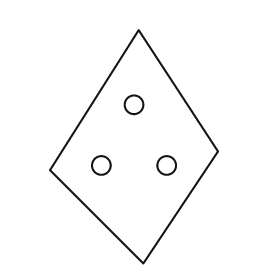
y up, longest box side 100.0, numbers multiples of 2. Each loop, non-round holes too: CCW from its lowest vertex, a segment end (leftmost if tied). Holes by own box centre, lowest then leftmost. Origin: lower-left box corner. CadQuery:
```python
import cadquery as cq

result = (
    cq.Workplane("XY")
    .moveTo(40.0, 0.0)
    .lineTo(72.0, 48.0)
    .lineTo(38.0, 100.0)
    .lineTo(0.0, 40.0)
    .close()
    .moveTo(22.0, 42.0)
    .circle(4.0)
    .moveTo(50.0, 42.0)
    .circle(4.0)
    .moveTo(36.0, 68.0)
    .circle(4.0)
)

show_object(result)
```